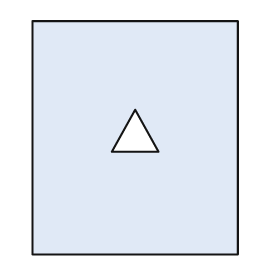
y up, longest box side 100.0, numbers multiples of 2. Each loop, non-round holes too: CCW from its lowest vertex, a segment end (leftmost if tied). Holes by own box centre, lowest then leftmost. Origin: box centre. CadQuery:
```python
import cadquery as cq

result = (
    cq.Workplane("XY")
    .moveTo(-44.0, -50.0)
    .lineTo(44.0, -50.0)
    .lineTo(44.0, 50.0)
    .lineTo(-44.0, 50.0)
    .close()
    .moveTo(-10.0, -6.0)
    .lineTo(10.0, -6.0)
    .lineTo(0.0, 12.0)
    .close()
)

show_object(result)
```